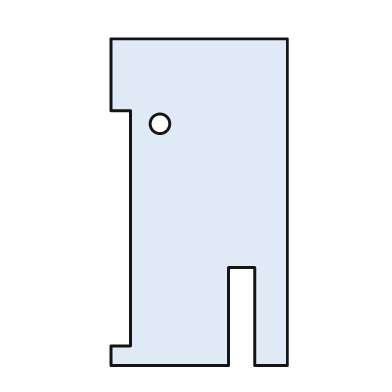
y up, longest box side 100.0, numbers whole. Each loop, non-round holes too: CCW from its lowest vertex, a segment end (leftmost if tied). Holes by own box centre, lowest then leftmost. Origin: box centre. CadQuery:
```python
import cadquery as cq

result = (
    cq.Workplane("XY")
    .moveTo(-27.0, -50.0)
    .lineTo(9.0, -50.0)
    .lineTo(9.0, -20.0)
    .lineTo(17.0, -20.0)
    .lineTo(17.0, -50.0)
    .lineTo(27.0, -50.0)
    .lineTo(27.0, 50.0)
    .lineTo(-27.0, 50.0)
    .lineTo(-27.0, 28.0)
    .lineTo(-21.0, 28.0)
    .lineTo(-21.0, -44.0)
    .lineTo(-27.0, -44.0)
    .close()
    .moveTo(-12.0, 24.0)
    .circle(3.0)
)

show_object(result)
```